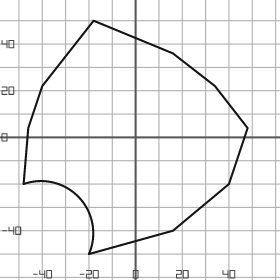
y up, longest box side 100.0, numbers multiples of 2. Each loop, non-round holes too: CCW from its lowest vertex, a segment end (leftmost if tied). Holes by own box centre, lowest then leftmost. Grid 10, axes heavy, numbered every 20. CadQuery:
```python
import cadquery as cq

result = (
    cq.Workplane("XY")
    .moveTo(-20.0, -50.0)
    .lineTo(16.0, -40.0)
    .lineTo(40.0, -20.0)
    .lineTo(48.0, 4.0)
    .lineTo(34.0, 22.0)
    .lineTo(16.0, 36.0)
    .lineTo(-18.0, 50.0)
    .lineTo(-40.0, 22.0)
    .lineTo(-46.0, 4.0)
    .lineTo(-48.0, -20.0)
    .threePointArc((-24.0, -26.0), (-20.0, -50.0))
    .close()
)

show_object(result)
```